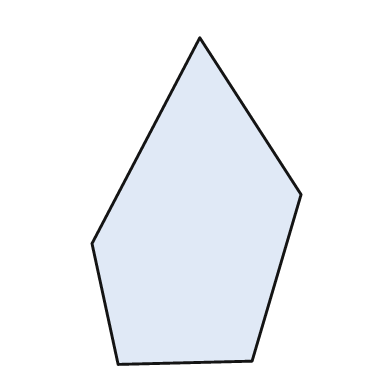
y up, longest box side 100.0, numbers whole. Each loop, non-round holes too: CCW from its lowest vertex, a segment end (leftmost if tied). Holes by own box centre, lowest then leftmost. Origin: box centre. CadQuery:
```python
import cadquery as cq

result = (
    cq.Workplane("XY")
    .moveTo(-24.0, -50.0)
    .lineTo(17.0, -49.0)
    .lineTo(32.0, 2.0)
    .lineTo(1.0, 50.0)
    .lineTo(-32.0, -13.0)
    .close()
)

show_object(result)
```